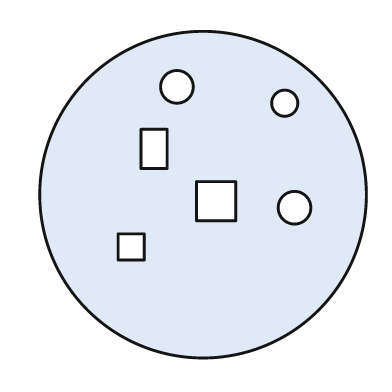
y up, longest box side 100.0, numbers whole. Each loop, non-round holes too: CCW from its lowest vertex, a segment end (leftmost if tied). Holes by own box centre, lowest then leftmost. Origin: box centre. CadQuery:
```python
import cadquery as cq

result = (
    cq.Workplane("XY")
    .moveTo(0.0, 0.0)
    .circle(50.0)
    .moveTo(-26.0, -20.0)
    .lineTo(-18.0, -20.0)
    .lineTo(-18.0, -12.0)
    .lineTo(-26.0, -12.0)
    .close()
    .moveTo(28.0, -4.0)
    .circle(5.0)
    .moveTo(-2.0, -8.0)
    .lineTo(10.0, -8.0)
    .lineTo(10.0, 4.0)
    .lineTo(-2.0, 4.0)
    .close()
    .moveTo(-19.0, 8.0)
    .lineTo(-11.0, 8.0)
    .lineTo(-11.0, 20.0)
    .lineTo(-19.0, 20.0)
    .close()
    .moveTo(25.0, 28.0)
    .circle(4.0)
    .moveTo(-8.0, 33.0)
    .circle(5.0)
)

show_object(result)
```